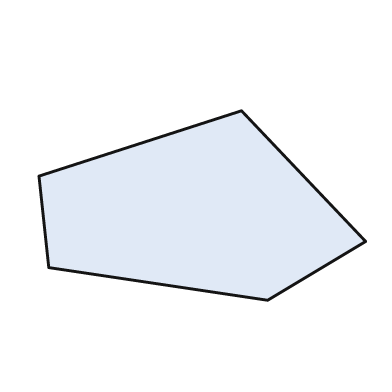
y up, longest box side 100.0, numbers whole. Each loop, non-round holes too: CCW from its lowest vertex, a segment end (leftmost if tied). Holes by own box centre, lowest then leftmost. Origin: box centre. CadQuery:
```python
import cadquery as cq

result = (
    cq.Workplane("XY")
    .moveTo(20.0, -29.0)
    .lineTo(50.0, -11.0)
    .lineTo(12.0, 29.0)
    .lineTo(-50.0, 9.0)
    .lineTo(-47.0, -19.0)
    .close()
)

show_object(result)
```